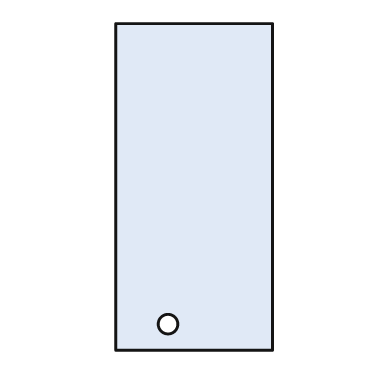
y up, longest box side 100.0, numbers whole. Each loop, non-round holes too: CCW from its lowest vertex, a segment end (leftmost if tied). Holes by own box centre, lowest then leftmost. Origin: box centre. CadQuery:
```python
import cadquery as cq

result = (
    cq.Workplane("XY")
    .moveTo(-24.0, -50.0)
    .lineTo(24.0, -50.0)
    .lineTo(24.0, 50.0)
    .lineTo(-24.0, 50.0)
    .close()
    .moveTo(-8.0, -42.0)
    .circle(3.0)
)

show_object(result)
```